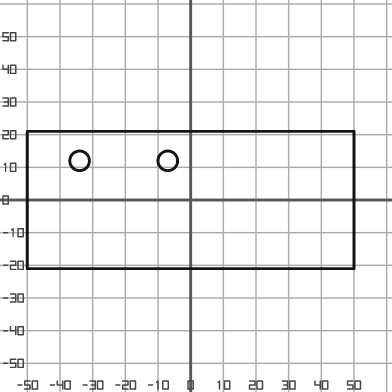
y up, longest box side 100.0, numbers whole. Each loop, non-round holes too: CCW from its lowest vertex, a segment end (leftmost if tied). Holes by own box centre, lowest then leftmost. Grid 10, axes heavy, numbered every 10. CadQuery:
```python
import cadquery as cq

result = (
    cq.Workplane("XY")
    .moveTo(-50.0, -21.0)
    .lineTo(50.0, -21.0)
    .lineTo(50.0, 21.0)
    .lineTo(-50.0, 21.0)
    .close()
    .moveTo(-34.0, 12.0)
    .circle(3.0)
    .moveTo(-7.0, 12.0)
    .circle(3.0)
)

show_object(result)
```